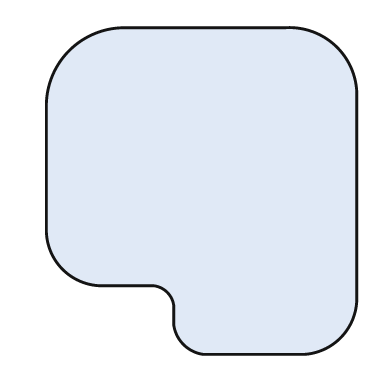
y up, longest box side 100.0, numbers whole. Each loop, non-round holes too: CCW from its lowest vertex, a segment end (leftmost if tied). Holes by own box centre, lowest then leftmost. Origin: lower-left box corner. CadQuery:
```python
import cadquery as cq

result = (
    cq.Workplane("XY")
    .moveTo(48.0, 0.0)
    .lineTo(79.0, 0.0)
    .threePointArc((90.0, 5.0), (95.0, 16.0))
    .lineTo(95.0, 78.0)
    .threePointArc((89.0, 94.0), (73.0, 100.0))
    .lineTo(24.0, 100.0)
    .threePointArc((7.0, 93.0), (0.0, 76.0))
    .lineTo(0.0, 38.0)
    .threePointArc((5.0, 26.0), (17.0, 21.0))
    .lineTo(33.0, 21.0)
    .threePointArc((37.0, 19.0), (39.0, 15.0))
    .lineTo(39.0, 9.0)
    .threePointArc((42.0, 3.0), (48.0, 0.0))
    .close()
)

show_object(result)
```